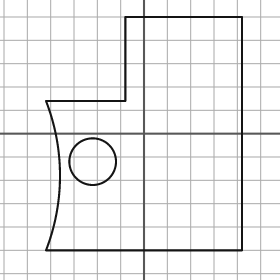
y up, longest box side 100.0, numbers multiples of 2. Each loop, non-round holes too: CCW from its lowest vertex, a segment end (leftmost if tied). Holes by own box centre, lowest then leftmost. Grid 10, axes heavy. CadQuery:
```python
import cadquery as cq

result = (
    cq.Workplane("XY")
    .moveTo(-42.0, -50.0)
    .lineTo(42.0, -50.0)
    .lineTo(42.0, 50.0)
    .lineTo(-8.0, 50.0)
    .lineTo(-8.0, 14.0)
    .lineTo(-42.0, 14.0)
    .threePointArc((-36.0, -18.0), (-42.0, -50.0))
    .close()
    .moveTo(-22.0, -12.0)
    .circle(10.0)
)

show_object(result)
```